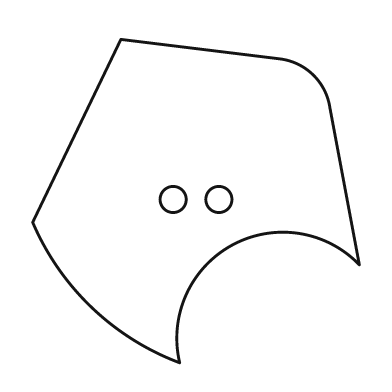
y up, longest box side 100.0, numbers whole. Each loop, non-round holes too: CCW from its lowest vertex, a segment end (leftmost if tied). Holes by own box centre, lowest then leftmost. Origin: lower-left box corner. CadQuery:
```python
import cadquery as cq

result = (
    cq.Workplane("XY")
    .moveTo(45.0, 0.0)
    .threePointArc((61.0, 36.0), (100.0, 30.0))
    .lineTo(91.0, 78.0)
    .threePointArc((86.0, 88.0), (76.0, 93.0))
    .lineTo(27.0, 99.0)
    .lineTo(0.0, 43.0)
    .threePointArc((18.0, 17.0), (45.0, 0.0))
    .close()
    .moveTo(43.0, 50.0)
    .circle(4.0)
    .moveTo(57.0, 50.0)
    .circle(4.0)
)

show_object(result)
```